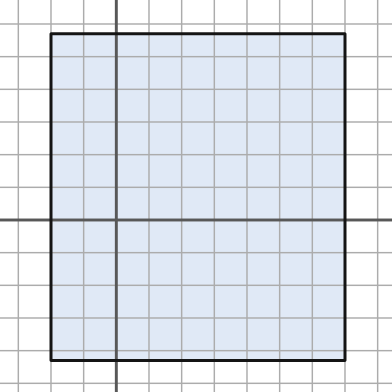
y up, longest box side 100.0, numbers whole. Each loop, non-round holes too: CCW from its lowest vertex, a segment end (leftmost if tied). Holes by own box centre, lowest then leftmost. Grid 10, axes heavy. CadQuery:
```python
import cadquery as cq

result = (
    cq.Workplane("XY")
    .moveTo(-20.0, -43.0)
    .lineTo(70.0, -43.0)
    .lineTo(70.0, 57.0)
    .lineTo(-20.0, 57.0)
    .close()
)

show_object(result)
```